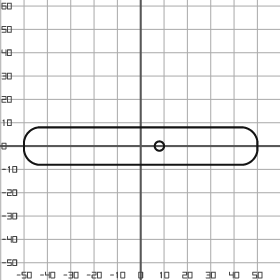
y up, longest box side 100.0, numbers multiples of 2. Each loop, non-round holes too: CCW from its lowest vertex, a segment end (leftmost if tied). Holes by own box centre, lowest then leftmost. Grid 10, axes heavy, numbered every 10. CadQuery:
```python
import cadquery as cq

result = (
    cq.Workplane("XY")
    .moveTo(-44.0, -8.0)
    .lineTo(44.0, -8.0)
    .threePointArc((48.0, -6.0), (50.0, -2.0))
    .lineTo(50.0, 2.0)
    .threePointArc((48.0, 6.0), (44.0, 8.0))
    .lineTo(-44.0, 8.0)
    .threePointArc((-48.0, 6.0), (-50.0, 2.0))
    .lineTo(-50.0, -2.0)
    .threePointArc((-48.0, -6.0), (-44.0, -8.0))
    .close()
    .moveTo(8.0, 0.0)
    .circle(2.0)
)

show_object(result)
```